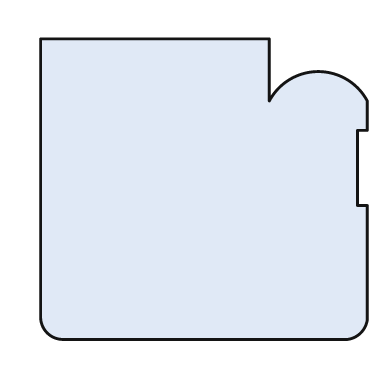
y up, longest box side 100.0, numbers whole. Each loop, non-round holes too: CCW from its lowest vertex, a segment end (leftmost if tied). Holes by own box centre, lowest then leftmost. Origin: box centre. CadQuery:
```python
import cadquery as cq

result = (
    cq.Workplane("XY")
    .moveTo(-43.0, -46.0)
    .lineTo(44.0, -46.0)
    .threePointArc((48.0, -44.0), (50.0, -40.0))
    .lineTo(50.0, -5.0)
    .lineTo(47.0, -5.0)
    .lineTo(47.0, 18.0)
    .lineTo(50.0, 18.0)
    .lineTo(50.0, 27.0)
    .threePointArc((35.0, 36.0), (20.0, 27.0))
    .lineTo(20.0, 46.0)
    .lineTo(-50.0, 46.0)
    .lineTo(-50.0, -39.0)
    .threePointArc((-48.0, -44.0), (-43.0, -46.0))
    .close()
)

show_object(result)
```